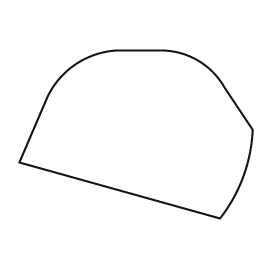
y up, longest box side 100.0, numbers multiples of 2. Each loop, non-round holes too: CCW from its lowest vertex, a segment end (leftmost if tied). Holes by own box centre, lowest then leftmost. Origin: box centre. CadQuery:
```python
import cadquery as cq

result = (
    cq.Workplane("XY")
    .moveTo(36.0, -36.0)
    .threePointArc((46.0, -18.0), (50.0, 2.0))
    .lineTo(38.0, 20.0)
    .threePointArc((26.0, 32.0), (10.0, 36.0))
    .lineTo(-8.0, 36.0)
    .threePointArc((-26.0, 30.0), (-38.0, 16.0))
    .lineTo(-50.0, -12.0)
    .close()
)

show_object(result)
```